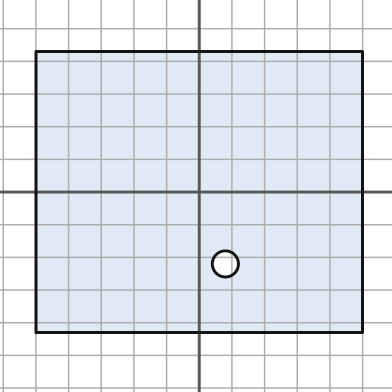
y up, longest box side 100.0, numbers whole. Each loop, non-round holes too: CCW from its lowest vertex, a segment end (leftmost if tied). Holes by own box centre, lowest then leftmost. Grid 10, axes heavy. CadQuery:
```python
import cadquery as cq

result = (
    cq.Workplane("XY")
    .moveTo(-50.0, -43.0)
    .lineTo(50.0, -43.0)
    .lineTo(50.0, 43.0)
    .lineTo(-50.0, 43.0)
    .close()
    .moveTo(8.0, -22.0)
    .circle(4.0)
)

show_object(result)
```